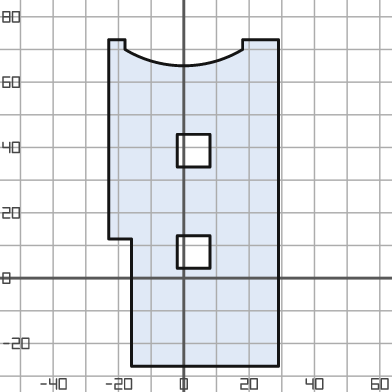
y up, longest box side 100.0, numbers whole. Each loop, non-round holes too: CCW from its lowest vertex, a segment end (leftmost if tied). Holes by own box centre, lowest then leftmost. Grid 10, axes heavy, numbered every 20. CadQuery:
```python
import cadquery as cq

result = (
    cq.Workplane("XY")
    .moveTo(-16.0, -27.0)
    .lineTo(29.0, -27.0)
    .lineTo(29.0, 73.0)
    .lineTo(18.0, 73.0)
    .lineTo(18.0, 70.0)
    .threePointArc((0.0, 65.0), (-18.0, 70.0))
    .lineTo(-18.0, 73.0)
    .lineTo(-23.0, 73.0)
    .lineTo(-23.0, 12.0)
    .lineTo(-16.0, 12.0)
    .close()
    .moveTo(-2.0, 3.0)
    .lineTo(8.0, 3.0)
    .lineTo(8.0, 13.0)
    .lineTo(-2.0, 13.0)
    .close()
    .moveTo(-2.0, 34.0)
    .lineTo(8.0, 34.0)
    .lineTo(8.0, 44.0)
    .lineTo(-2.0, 44.0)
    .close()
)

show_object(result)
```